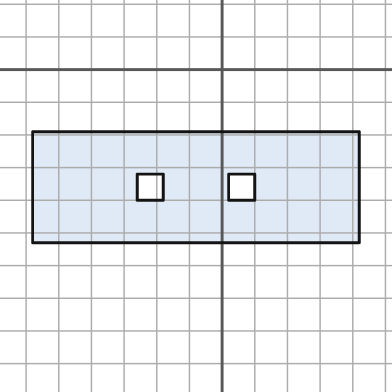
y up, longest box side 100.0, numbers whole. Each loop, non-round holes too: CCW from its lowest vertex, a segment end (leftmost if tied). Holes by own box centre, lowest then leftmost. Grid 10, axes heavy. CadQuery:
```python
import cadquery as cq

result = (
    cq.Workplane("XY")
    .moveTo(-58.0, -53.0)
    .lineTo(42.0, -53.0)
    .lineTo(42.0, -19.0)
    .lineTo(-58.0, -19.0)
    .close()
    .moveTo(-26.0, -40.0)
    .lineTo(-18.0, -40.0)
    .lineTo(-18.0, -32.0)
    .lineTo(-26.0, -32.0)
    .close()
    .moveTo(2.0, -40.0)
    .lineTo(10.0, -40.0)
    .lineTo(10.0, -32.0)
    .lineTo(2.0, -32.0)
    .close()
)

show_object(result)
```